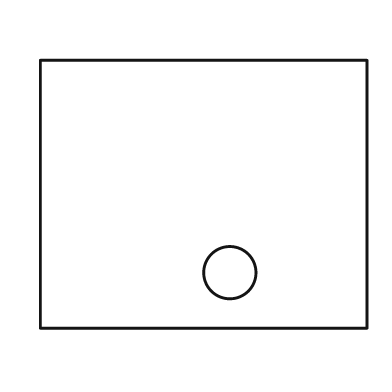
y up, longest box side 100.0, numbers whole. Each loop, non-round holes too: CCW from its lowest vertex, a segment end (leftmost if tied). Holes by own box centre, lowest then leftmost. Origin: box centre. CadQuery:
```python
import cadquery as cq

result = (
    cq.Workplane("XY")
    .moveTo(-50.0, -41.0)
    .lineTo(50.0, -41.0)
    .lineTo(50.0, 41.0)
    .lineTo(-50.0, 41.0)
    .close()
    .moveTo(8.0, -24.0)
    .circle(8.0)
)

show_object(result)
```